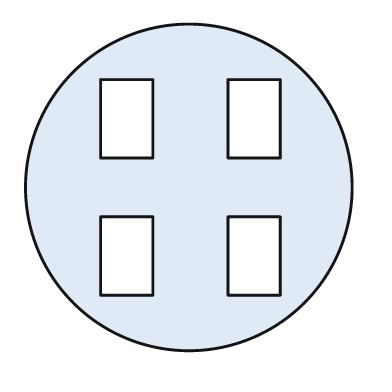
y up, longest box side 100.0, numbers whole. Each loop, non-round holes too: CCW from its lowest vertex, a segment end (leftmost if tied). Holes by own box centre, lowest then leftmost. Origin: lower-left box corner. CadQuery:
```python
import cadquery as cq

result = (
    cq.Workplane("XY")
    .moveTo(50.0, 50.0)
    .circle(50.0)
    .moveTo(23.0, 17.0)
    .lineTo(39.0, 17.0)
    .lineTo(39.0, 41.0)
    .lineTo(23.0, 41.0)
    .close()
    .moveTo(62.0, 17.0)
    .lineTo(78.0, 17.0)
    .lineTo(78.0, 41.0)
    .lineTo(62.0, 41.0)
    .close()
    .moveTo(23.0, 59.0)
    .lineTo(39.0, 59.0)
    .lineTo(39.0, 83.0)
    .lineTo(23.0, 83.0)
    .close()
    .moveTo(62.0, 59.0)
    .lineTo(78.0, 59.0)
    .lineTo(78.0, 83.0)
    .lineTo(62.0, 83.0)
    .close()
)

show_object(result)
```